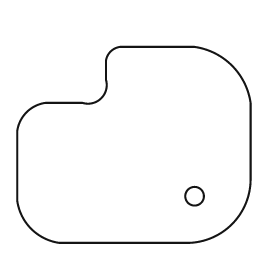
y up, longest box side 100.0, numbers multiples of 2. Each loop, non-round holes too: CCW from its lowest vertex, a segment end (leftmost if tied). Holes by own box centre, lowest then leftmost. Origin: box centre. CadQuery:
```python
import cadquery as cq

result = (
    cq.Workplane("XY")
    .moveTo(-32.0, -42.0)
    .lineTo(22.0, -42.0)
    .threePointArc((42.0, -34.0), (50.0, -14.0))
    .lineTo(50.0, 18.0)
    .threePointArc((42.0, 34.0), (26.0, 42.0))
    .lineTo(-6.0, 42.0)
    .threePointArc((-10.0, 40.0), (-12.0, 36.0))
    .lineTo(-12.0, 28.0)
    .threePointArc((-14.0, 20.0), (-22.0, 18.0))
    .lineTo(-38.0, 18.0)
    .threePointArc((-46.0, 14.0), (-50.0, 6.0))
    .lineTo(-50.0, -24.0)
    .threePointArc((-44.0, -36.0), (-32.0, -42.0))
    .close()
    .moveTo(26.0, -22.0)
    .circle(4.0)
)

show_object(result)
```